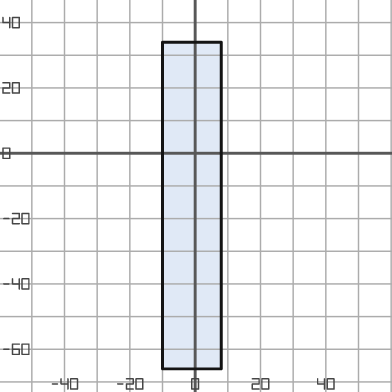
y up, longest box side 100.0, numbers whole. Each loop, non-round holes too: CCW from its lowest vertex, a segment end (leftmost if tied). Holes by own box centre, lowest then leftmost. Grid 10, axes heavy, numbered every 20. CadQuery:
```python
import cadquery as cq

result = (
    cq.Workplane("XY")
    .moveTo(-10.0, -66.0)
    .lineTo(8.0, -66.0)
    .lineTo(8.0, 34.0)
    .lineTo(-10.0, 34.0)
    .close()
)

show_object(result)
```